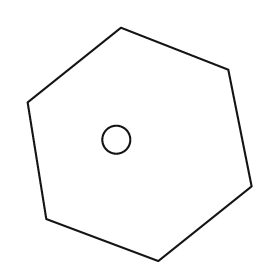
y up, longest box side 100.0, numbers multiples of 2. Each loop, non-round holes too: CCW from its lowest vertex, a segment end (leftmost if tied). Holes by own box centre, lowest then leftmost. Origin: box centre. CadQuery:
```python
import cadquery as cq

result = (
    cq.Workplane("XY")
    .moveTo(8.0, -50.0)
    .lineTo(48.0, -18.0)
    .lineTo(38.0, 32.0)
    .lineTo(-8.0, 50.0)
    .lineTo(-48.0, 18.0)
    .lineTo(-40.0, -32.0)
    .close()
    .moveTo(-10.0, 2.0)
    .circle(6.0)
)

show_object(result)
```